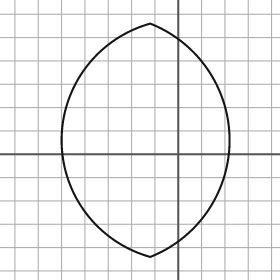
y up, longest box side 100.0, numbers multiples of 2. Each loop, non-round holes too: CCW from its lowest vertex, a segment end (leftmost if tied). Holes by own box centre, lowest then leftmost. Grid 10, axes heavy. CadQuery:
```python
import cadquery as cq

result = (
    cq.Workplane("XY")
    .moveTo(-12.0, -44.0)
    .threePointArc((22.0, 6.0), (-12.0, 56.0))
    .threePointArc((-50.0, 6.0), (-12.0, -44.0))
    .close()
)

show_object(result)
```